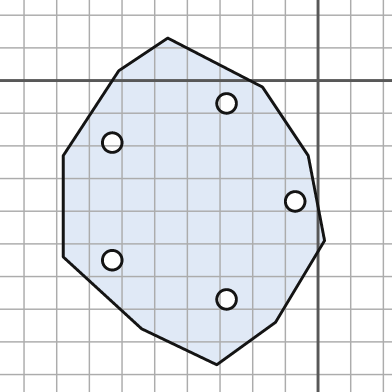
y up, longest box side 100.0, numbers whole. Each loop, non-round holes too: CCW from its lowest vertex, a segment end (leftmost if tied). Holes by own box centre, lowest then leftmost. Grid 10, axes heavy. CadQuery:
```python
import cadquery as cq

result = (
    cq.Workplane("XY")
    .moveTo(-31.0, -87.0)
    .lineTo(-13.0, -74.0)
    .lineTo(2.0, -49.0)
    .lineTo(-3.0, -23.0)
    .lineTo(-17.0, -2.0)
    .lineTo(-46.0, 13.0)
    .lineTo(-61.0, 3.0)
    .lineTo(-78.0, -23.0)
    .lineTo(-78.0, -54.0)
    .lineTo(-54.0, -76.0)
    .close()
    .moveTo(-28.0, -67.0)
    .circle(3.0)
    .moveTo(-63.0, -55.0)
    .circle(3.0)
    .moveTo(-7.0, -37.0)
    .circle(3.0)
    .moveTo(-63.0, -19.0)
    .circle(3.0)
    .moveTo(-28.0, -7.0)
    .circle(3.0)
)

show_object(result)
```